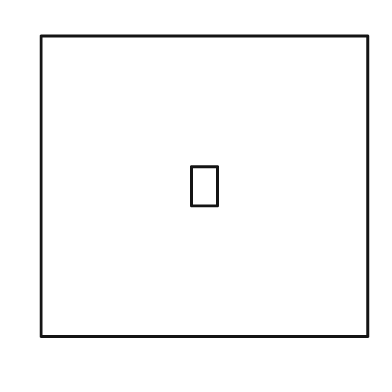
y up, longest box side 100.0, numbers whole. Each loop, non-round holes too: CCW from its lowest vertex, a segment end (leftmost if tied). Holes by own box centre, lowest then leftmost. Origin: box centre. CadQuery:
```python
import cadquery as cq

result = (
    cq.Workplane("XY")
    .moveTo(-50.0, -46.0)
    .lineTo(50.0, -46.0)
    .lineTo(50.0, 46.0)
    .lineTo(-50.0, 46.0)
    .close()
    .moveTo(-4.0, -6.0)
    .lineTo(4.0, -6.0)
    .lineTo(4.0, 6.0)
    .lineTo(-4.0, 6.0)
    .close()
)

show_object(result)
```